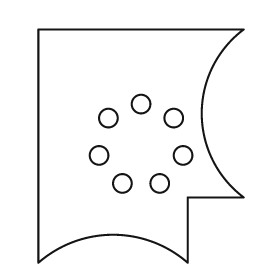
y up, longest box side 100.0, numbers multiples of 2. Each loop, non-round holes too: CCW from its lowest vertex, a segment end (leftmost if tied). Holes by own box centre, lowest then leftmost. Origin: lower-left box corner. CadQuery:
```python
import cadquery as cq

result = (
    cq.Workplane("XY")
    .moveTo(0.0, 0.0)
    .threePointArc((32.0, 12.0), (64.0, 0.0))
    .lineTo(64.0, 28.0)
    .lineTo(88.0, 28.0)
    .threePointArc((70.0, 64.0), (88.0, 100.0))
    .lineTo(0.0, 100.0)
    .close()
    .moveTo(36.0, 34.0)
    .circle(4.0)
    .moveTo(52.0, 34.0)
    .circle(4.0)
    .moveTo(26.0, 46.0)
    .circle(4.0)
    .moveTo(62.0, 46.0)
    .circle(4.0)
    .moveTo(30.0, 62.0)
    .circle(4.0)
    .moveTo(58.0, 62.0)
    .circle(4.0)
    .moveTo(44.0, 68.0)
    .circle(4.0)
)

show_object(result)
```